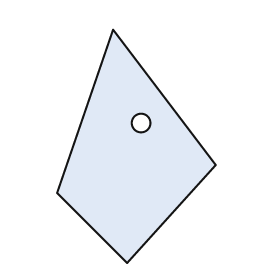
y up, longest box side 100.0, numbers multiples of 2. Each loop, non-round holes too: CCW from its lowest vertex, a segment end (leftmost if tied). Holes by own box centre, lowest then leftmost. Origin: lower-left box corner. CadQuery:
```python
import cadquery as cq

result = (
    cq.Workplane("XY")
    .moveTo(30.0, 0.0)
    .lineTo(68.0, 42.0)
    .lineTo(24.0, 100.0)
    .lineTo(0.0, 30.0)
    .close()
    .moveTo(36.0, 60.0)
    .circle(4.0)
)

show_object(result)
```